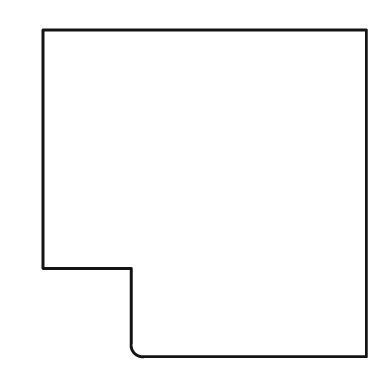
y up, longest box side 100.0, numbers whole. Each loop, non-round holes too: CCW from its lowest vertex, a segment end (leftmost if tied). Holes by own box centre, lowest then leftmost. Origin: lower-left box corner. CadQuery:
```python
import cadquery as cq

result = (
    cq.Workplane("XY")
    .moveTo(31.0, 0.0)
    .lineTo(99.0, 0.0)
    .lineTo(99.0, 100.0)
    .lineTo(0.0, 100.0)
    .lineTo(0.0, 27.0)
    .lineTo(27.0, 27.0)
    .lineTo(27.0, 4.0)
    .threePointArc((28.0, 1.0), (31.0, 0.0))
    .close()
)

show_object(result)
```